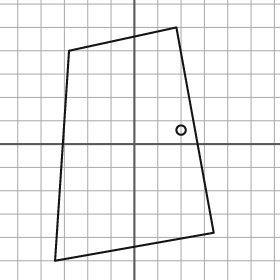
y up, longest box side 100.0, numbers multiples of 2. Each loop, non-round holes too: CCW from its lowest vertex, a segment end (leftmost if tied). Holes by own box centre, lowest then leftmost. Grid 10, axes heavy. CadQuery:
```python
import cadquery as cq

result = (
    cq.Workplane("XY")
    .moveTo(-34.0, -50.0)
    .lineTo(34.0, -38.0)
    .lineTo(18.0, 50.0)
    .lineTo(-28.0, 40.0)
    .close()
    .moveTo(20.0, 6.0)
    .circle(2.0)
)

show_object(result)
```